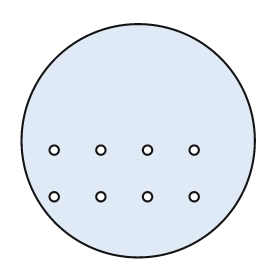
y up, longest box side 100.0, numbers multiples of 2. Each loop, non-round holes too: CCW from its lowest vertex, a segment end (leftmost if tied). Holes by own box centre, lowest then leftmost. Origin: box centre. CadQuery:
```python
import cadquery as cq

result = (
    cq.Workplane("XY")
    .moveTo(0.0, 0.0)
    .circle(50.0)
    .moveTo(-36.0, -24.0)
    .circle(2.0)
    .moveTo(-16.0, -24.0)
    .circle(2.0)
    .moveTo(4.0, -24.0)
    .circle(2.0)
    .moveTo(24.0, -24.0)
    .circle(2.0)
    .moveTo(-36.0, -4.0)
    .circle(2.0)
    .moveTo(-16.0, -4.0)
    .circle(2.0)
    .moveTo(4.0, -4.0)
    .circle(2.0)
    .moveTo(24.0, -4.0)
    .circle(2.0)
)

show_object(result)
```